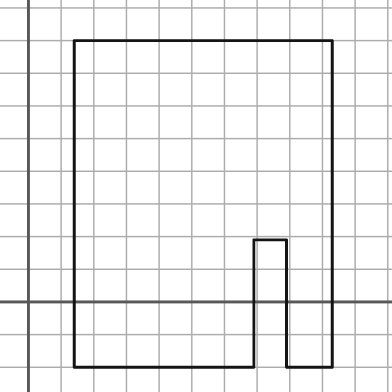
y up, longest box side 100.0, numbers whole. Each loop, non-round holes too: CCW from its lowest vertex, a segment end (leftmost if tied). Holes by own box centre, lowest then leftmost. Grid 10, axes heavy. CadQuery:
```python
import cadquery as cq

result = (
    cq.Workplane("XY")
    .moveTo(14.0, -20.0)
    .lineTo(69.0, -20.0)
    .lineTo(69.0, 19.0)
    .lineTo(79.0, 19.0)
    .lineTo(79.0, -20.0)
    .lineTo(93.0, -20.0)
    .lineTo(93.0, 80.0)
    .lineTo(14.0, 80.0)
    .close()
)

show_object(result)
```